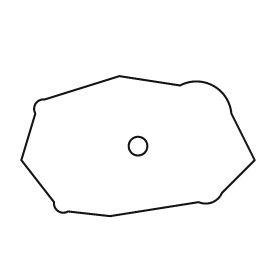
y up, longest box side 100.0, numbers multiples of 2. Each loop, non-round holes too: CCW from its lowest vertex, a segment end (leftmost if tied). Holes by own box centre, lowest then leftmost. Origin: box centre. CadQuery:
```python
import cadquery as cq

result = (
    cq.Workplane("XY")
    .moveTo(-12.0, -30.0)
    .lineTo(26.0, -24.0)
    .threePointArc((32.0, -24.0), (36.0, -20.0))
    .lineTo(50.0, -6.0)
    .lineTo(40.0, 14.0)
    .threePointArc((32.0, 26.0), (18.0, 26.0))
    .lineTo(-8.0, 30.0)
    .lineTo(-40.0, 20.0)
    .threePointArc((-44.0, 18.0), (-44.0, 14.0))
    .lineTo(-50.0, -6.0)
    .lineTo(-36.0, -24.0)
    .threePointArc((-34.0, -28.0), (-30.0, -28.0))
    .close()
    .moveTo(0.0, 0.0)
    .circle(4.0)
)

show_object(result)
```